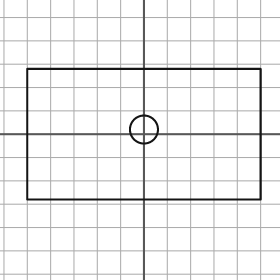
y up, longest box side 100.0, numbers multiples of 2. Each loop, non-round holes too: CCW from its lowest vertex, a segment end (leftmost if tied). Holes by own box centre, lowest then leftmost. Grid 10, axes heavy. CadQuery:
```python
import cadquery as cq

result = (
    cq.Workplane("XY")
    .moveTo(-50.0, -28.0)
    .lineTo(50.0, -28.0)
    .lineTo(50.0, 28.0)
    .lineTo(-50.0, 28.0)
    .close()
    .moveTo(0.0, 2.0)
    .circle(6.0)
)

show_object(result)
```